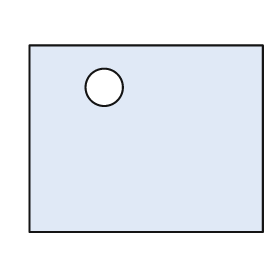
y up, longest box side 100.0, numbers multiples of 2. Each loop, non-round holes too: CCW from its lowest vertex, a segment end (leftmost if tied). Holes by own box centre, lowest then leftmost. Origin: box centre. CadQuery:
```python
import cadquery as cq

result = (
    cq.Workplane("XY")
    .moveTo(-50.0, -40.0)
    .lineTo(50.0, -40.0)
    .lineTo(50.0, 40.0)
    .lineTo(-50.0, 40.0)
    .close()
    .moveTo(-18.0, 22.0)
    .circle(8.0)
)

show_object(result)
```